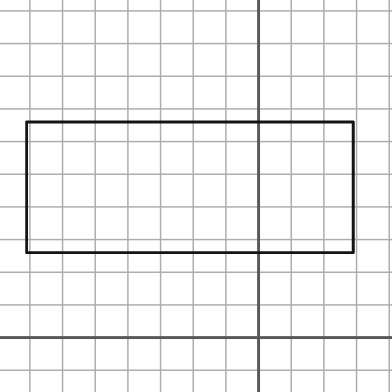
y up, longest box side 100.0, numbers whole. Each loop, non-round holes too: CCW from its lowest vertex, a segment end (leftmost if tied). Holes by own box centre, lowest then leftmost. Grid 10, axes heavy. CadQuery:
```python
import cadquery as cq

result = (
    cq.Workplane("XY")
    .moveTo(-71.0, 26.0)
    .lineTo(29.0, 26.0)
    .lineTo(29.0, 66.0)
    .lineTo(-71.0, 66.0)
    .close()
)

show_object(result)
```